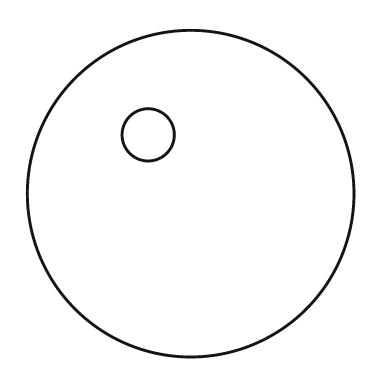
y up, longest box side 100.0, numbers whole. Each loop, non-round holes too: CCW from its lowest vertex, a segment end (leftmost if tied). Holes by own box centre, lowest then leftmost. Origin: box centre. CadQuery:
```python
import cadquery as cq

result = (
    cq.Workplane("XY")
    .moveTo(0.0, 0.0)
    .circle(50.0)
    .moveTo(-13.0, 18.0)
    .circle(8.0)
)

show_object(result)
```